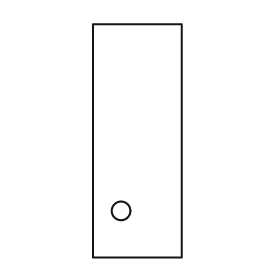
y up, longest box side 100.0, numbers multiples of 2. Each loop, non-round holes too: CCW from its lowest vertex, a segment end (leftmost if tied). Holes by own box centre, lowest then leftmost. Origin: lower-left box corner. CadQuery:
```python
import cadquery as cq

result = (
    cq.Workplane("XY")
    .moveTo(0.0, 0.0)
    .lineTo(38.0, 0.0)
    .lineTo(38.0, 100.0)
    .lineTo(0.0, 100.0)
    .close()
    .moveTo(12.0, 20.0)
    .circle(4.0)
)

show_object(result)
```